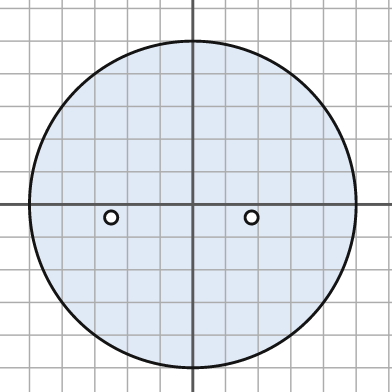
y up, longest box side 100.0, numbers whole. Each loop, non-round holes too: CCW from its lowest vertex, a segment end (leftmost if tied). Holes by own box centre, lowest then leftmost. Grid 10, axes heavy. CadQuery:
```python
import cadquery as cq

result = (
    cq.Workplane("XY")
    .moveTo(0.0, 0.0)
    .circle(50.0)
    .moveTo(-25.0, -4.0)
    .circle(2.0)
    .moveTo(18.0, -4.0)
    .circle(2.0)
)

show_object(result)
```